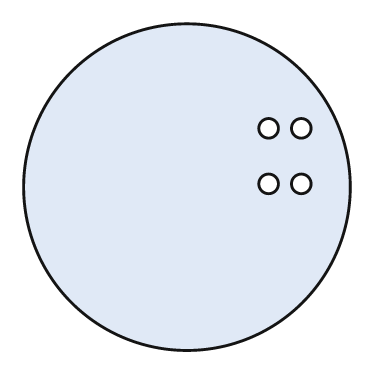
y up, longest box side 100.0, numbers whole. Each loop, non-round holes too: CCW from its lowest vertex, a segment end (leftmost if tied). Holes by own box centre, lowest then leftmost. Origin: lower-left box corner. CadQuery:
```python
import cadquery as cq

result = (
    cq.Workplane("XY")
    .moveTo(50.0, 50.0)
    .circle(50.0)
    .moveTo(75.0, 51.0)
    .circle(3.0)
    .moveTo(85.0, 51.0)
    .circle(3.0)
    .moveTo(75.0, 68.0)
    .circle(3.0)
    .moveTo(85.0, 68.0)
    .circle(3.0)
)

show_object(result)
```